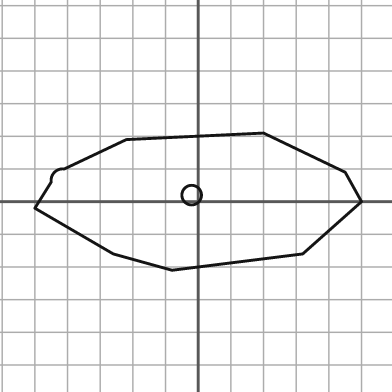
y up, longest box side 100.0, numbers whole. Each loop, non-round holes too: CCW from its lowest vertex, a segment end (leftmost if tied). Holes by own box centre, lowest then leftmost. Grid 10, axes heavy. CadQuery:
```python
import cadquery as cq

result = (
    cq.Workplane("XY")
    .moveTo(-8.0, -21.0)
    .lineTo(32.0, -16.0)
    .lineTo(50.0, 0.0)
    .lineTo(45.0, 9.0)
    .lineTo(20.0, 21.0)
    .lineTo(-22.0, 19.0)
    .lineTo(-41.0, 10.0)
    .threePointArc((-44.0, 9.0), (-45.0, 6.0))
    .lineTo(-50.0, -2.0)
    .lineTo(-26.0, -16.0)
    .close()
    .moveTo(-2.0, 2.0)
    .circle(3.0)
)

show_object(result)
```